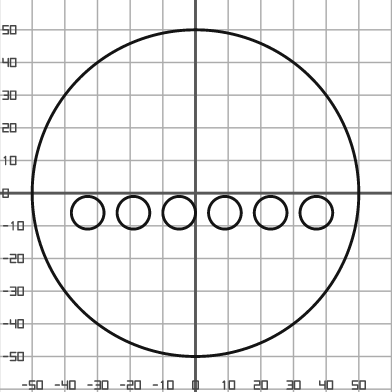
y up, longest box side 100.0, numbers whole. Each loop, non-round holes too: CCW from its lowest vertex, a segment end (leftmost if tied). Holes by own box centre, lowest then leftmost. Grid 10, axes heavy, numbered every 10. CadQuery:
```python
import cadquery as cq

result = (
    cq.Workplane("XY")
    .moveTo(0.0, 0.0)
    .circle(50.0)
    .moveTo(-33.0, -6.0)
    .circle(5.0)
    .moveTo(-19.0, -6.0)
    .circle(5.0)
    .moveTo(-5.0, -6.0)
    .circle(5.0)
    .moveTo(9.0, -6.0)
    .circle(5.0)
    .moveTo(23.0, -6.0)
    .circle(5.0)
    .moveTo(37.0, -6.0)
    .circle(5.0)
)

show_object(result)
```